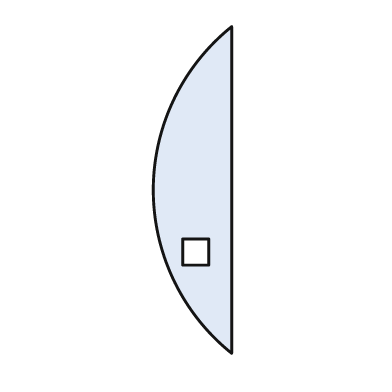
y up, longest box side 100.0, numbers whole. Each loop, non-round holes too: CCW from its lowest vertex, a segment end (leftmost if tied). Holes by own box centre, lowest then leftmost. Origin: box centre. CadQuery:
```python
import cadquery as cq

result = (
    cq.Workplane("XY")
    .moveTo(12.0, -50.0)
    .lineTo(12.0, 50.0)
    .threePointArc((-12.0, 0.0), (12.0, -50.0))
    .close()
    .moveTo(-3.0, -23.0)
    .lineTo(5.0, -23.0)
    .lineTo(5.0, -15.0)
    .lineTo(-3.0, -15.0)
    .close()
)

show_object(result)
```